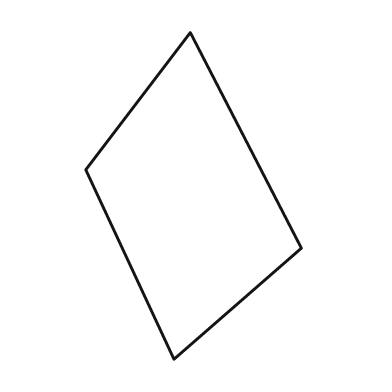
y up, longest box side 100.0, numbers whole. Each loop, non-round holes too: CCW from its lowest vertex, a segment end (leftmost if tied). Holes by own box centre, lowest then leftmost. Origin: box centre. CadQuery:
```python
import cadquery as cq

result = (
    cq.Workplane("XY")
    .moveTo(-6.0, -50.0)
    .lineTo(33.0, -16.0)
    .lineTo(-1.0, 50.0)
    .lineTo(-33.0, 8.0)
    .close()
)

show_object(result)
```